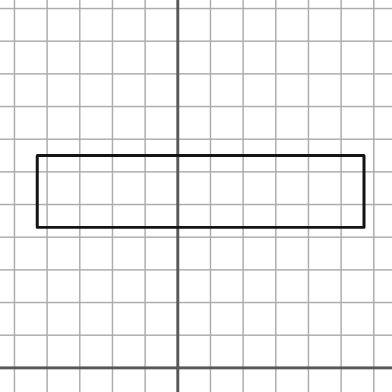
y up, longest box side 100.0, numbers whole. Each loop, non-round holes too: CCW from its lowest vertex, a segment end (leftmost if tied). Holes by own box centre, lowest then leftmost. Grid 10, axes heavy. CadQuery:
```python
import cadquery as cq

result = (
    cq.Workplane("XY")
    .moveTo(-43.0, 43.0)
    .lineTo(57.0, 43.0)
    .lineTo(57.0, 65.0)
    .lineTo(-43.0, 65.0)
    .close()
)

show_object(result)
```